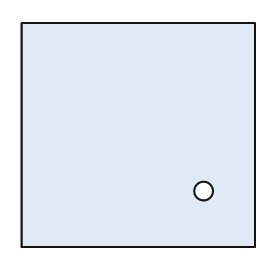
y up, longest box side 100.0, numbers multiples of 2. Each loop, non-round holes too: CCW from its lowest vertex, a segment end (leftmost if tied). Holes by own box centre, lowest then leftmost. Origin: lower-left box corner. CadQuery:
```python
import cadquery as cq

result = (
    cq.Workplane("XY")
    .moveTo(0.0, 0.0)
    .lineTo(100.0, 0.0)
    .lineTo(100.0, 96.0)
    .lineTo(0.0, 96.0)
    .close()
    .moveTo(78.0, 24.0)
    .circle(4.0)
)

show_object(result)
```